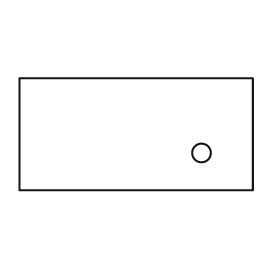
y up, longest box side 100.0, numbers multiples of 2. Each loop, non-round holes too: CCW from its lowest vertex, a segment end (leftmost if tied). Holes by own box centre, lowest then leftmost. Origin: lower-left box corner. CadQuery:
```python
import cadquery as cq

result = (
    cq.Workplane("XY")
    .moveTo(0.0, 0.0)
    .lineTo(100.0, 0.0)
    .lineTo(100.0, 48.0)
    .lineTo(0.0, 48.0)
    .close()
    .moveTo(78.0, 16.0)
    .circle(4.0)
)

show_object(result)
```